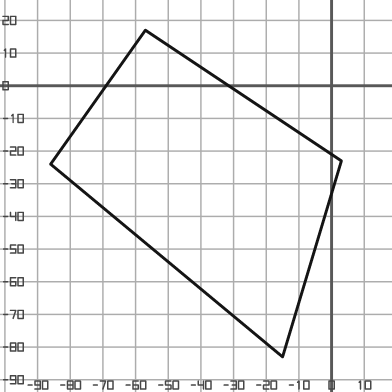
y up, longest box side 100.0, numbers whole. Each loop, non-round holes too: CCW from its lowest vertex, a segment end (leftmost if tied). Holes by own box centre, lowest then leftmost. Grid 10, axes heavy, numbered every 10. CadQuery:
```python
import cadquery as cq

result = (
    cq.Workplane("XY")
    .moveTo(-15.0, -83.0)
    .lineTo(3.0, -23.0)
    .lineTo(-57.0, 17.0)
    .lineTo(-86.0, -24.0)
    .close()
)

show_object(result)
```